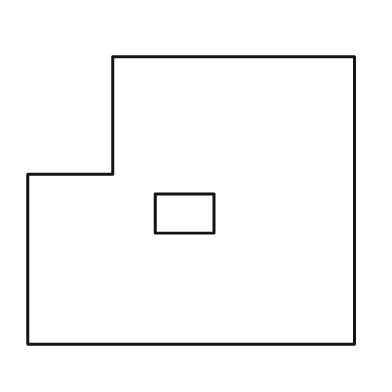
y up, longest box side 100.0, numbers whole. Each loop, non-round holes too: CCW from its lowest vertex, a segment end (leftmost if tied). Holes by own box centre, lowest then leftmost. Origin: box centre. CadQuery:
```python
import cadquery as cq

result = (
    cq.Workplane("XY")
    .moveTo(-50.0, -44.0)
    .lineTo(50.0, -44.0)
    .lineTo(50.0, 44.0)
    .lineTo(-24.0, 44.0)
    .lineTo(-24.0, 8.0)
    .lineTo(-50.0, 8.0)
    .close()
    .moveTo(-11.0, -10.0)
    .lineTo(7.0, -10.0)
    .lineTo(7.0, 2.0)
    .lineTo(-11.0, 2.0)
    .close()
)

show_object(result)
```